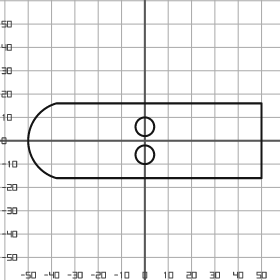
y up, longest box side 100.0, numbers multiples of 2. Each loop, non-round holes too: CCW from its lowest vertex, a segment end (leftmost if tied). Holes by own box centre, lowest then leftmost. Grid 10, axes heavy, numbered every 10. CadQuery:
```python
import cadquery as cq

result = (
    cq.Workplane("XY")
    .moveTo(-38.0, -16.0)
    .lineTo(50.0, -16.0)
    .lineTo(50.0, 16.0)
    .lineTo(-38.0, 16.0)
    .threePointArc((-50.0, 0.0), (-38.0, -16.0))
    .close()
    .moveTo(0.0, -6.0)
    .circle(4.0)
    .moveTo(0.0, 6.0)
    .circle(4.0)
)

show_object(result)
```